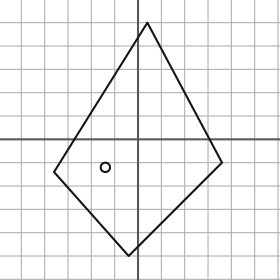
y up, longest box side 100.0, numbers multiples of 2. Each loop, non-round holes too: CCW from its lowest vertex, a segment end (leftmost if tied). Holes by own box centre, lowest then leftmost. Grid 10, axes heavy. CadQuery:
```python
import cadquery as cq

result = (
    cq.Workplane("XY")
    .moveTo(-4.0, -50.0)
    .lineTo(36.0, -10.0)
    .lineTo(4.0, 50.0)
    .lineTo(-36.0, -14.0)
    .close()
    .moveTo(-14.0, -12.0)
    .circle(2.0)
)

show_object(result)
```